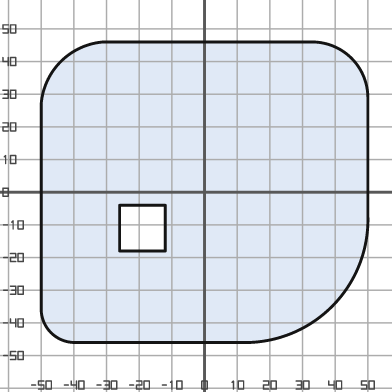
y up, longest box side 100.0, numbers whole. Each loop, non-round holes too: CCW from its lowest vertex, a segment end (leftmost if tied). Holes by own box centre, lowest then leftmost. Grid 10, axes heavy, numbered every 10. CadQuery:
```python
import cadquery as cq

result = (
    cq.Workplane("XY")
    .moveTo(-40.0, -46.0)
    .lineTo(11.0, -46.0)
    .threePointArc((39.0, -35.0), (50.0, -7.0))
    .lineTo(50.0, 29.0)
    .threePointArc((45.0, 41.0), (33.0, 46.0))
    .lineTo(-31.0, 46.0)
    .threePointArc((-44.0, 40.0), (-50.0, 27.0))
    .lineTo(-50.0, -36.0)
    .threePointArc((-47.0, -43.0), (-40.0, -46.0))
    .close()
    .moveTo(-26.0, -18.0)
    .lineTo(-12.0, -18.0)
    .lineTo(-12.0, -4.0)
    .lineTo(-26.0, -4.0)
    .close()
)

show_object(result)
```